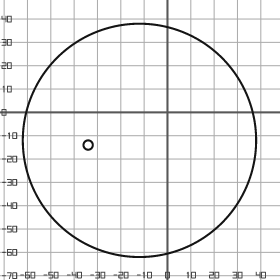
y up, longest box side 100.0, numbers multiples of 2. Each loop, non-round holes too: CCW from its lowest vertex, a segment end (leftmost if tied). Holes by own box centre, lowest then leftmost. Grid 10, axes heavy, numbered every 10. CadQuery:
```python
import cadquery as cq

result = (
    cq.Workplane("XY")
    .moveTo(-12.0, -12.0)
    .circle(50.0)
    .moveTo(-34.0, -14.0)
    .circle(2.0)
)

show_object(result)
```